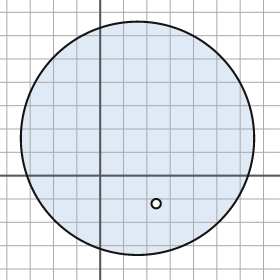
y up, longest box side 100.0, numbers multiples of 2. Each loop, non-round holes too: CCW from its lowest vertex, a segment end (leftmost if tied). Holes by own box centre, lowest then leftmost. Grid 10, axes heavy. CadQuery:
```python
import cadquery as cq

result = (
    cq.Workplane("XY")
    .moveTo(16.0, 16.0)
    .circle(50.0)
    .moveTo(24.0, -12.0)
    .circle(2.0)
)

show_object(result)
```